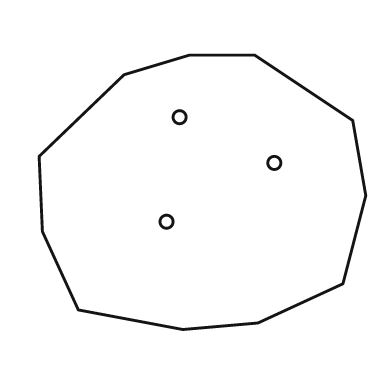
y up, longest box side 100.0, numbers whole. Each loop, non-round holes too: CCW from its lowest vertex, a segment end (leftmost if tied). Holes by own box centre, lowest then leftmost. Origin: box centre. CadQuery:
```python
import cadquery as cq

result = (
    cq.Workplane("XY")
    .moveTo(-6.0, -42.0)
    .lineTo(17.0, -40.0)
    .lineTo(43.0, -28.0)
    .lineTo(50.0, -1.0)
    .lineTo(46.0, 22.0)
    .lineTo(16.0, 42.0)
    .lineTo(-4.0, 42.0)
    .lineTo(-24.0, 36.0)
    .lineTo(-50.0, 11.0)
    .lineTo(-49.0, -12.0)
    .lineTo(-38.0, -36.0)
    .close()
    .moveTo(-11.0, -9.0)
    .circle(2.0)
    .moveTo(22.0, 9.0)
    .circle(2.0)
    .moveTo(-7.0, 23.0)
    .circle(2.0)
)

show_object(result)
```